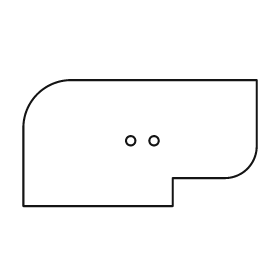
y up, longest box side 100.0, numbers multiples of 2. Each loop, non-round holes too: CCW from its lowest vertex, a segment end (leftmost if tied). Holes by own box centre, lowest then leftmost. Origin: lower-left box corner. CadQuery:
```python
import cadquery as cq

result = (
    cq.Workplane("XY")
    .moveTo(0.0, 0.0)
    .lineTo(64.0, 0.0)
    .lineTo(64.0, 12.0)
    .lineTo(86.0, 12.0)
    .threePointArc((96.0, 16.0), (100.0, 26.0))
    .lineTo(100.0, 54.0)
    .lineTo(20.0, 54.0)
    .threePointArc((6.0, 48.0), (0.0, 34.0))
    .close()
    .moveTo(46.0, 28.0)
    .circle(2.0)
    .moveTo(56.0, 28.0)
    .circle(2.0)
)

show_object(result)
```